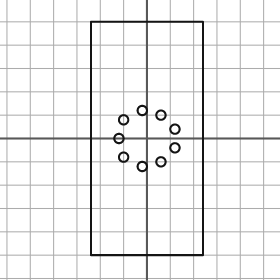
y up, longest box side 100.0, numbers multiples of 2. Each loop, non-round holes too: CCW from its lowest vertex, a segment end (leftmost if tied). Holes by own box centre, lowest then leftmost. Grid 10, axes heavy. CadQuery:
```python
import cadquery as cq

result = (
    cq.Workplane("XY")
    .moveTo(-24.0, -50.0)
    .lineTo(24.0, -50.0)
    .lineTo(24.0, 50.0)
    .lineTo(-24.0, 50.0)
    .close()
    .moveTo(-2.0, -12.0)
    .circle(2.0)
    .moveTo(6.0, -10.0)
    .circle(2.0)
    .moveTo(-10.0, -8.0)
    .circle(2.0)
    .moveTo(12.0, -4.0)
    .circle(2.0)
    .moveTo(-12.0, 0.0)
    .circle(2.0)
    .moveTo(12.0, 4.0)
    .circle(2.0)
    .moveTo(-10.0, 8.0)
    .circle(2.0)
    .moveTo(6.0, 10.0)
    .circle(2.0)
    .moveTo(-2.0, 12.0)
    .circle(2.0)
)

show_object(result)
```